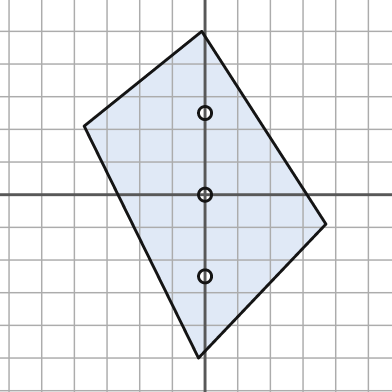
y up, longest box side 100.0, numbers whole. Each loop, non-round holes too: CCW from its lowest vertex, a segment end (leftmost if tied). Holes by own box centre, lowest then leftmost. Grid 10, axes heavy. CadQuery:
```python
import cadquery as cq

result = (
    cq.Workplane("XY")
    .moveTo(-2.0, -50.0)
    .lineTo(37.0, -9.0)
    .lineTo(-1.0, 50.0)
    .lineTo(-37.0, 21.0)
    .close()
    .moveTo(0.0, -25.0)
    .circle(2.0)
    .moveTo(0.0, 0.0)
    .circle(2.0)
    .moveTo(0.0, 25.0)
    .circle(2.0)
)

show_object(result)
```